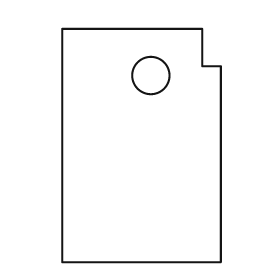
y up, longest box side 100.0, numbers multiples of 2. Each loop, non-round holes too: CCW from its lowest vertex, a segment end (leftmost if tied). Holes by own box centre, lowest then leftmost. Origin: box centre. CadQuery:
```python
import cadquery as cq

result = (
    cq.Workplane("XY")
    .moveTo(-34.0, -50.0)
    .lineTo(34.0, -50.0)
    .lineTo(34.0, 34.0)
    .lineTo(26.0, 34.0)
    .lineTo(26.0, 50.0)
    .lineTo(-34.0, 50.0)
    .close()
    .moveTo(4.0, 30.0)
    .circle(8.0)
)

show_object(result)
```